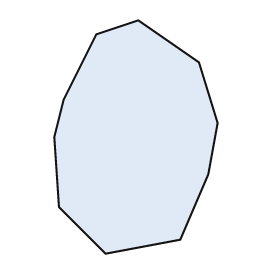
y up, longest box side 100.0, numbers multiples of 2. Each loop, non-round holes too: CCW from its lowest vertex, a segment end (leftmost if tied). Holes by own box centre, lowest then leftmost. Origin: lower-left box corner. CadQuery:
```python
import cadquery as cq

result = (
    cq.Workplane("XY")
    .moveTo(22.0, 0.0)
    .lineTo(54.0, 6.0)
    .lineTo(66.0, 34.0)
    .lineTo(70.0, 56.0)
    .lineTo(62.0, 82.0)
    .lineTo(36.0, 100.0)
    .lineTo(18.0, 94.0)
    .lineTo(4.0, 66.0)
    .lineTo(0.0, 50.0)
    .lineTo(2.0, 20.0)
    .close()
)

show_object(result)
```